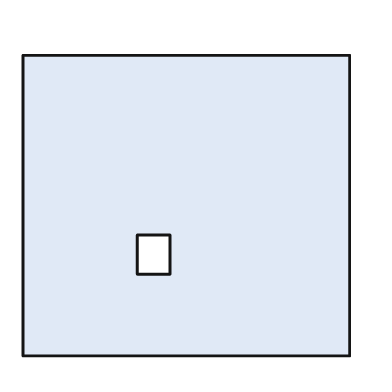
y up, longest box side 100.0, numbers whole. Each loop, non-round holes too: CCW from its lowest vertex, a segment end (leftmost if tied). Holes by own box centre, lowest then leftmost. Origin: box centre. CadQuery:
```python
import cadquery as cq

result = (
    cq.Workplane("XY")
    .moveTo(-50.0, -46.0)
    .lineTo(50.0, -46.0)
    .lineTo(50.0, 46.0)
    .lineTo(-50.0, 46.0)
    .close()
    .moveTo(-15.0, -21.0)
    .lineTo(-5.0, -21.0)
    .lineTo(-5.0, -9.0)
    .lineTo(-15.0, -9.0)
    .close()
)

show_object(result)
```